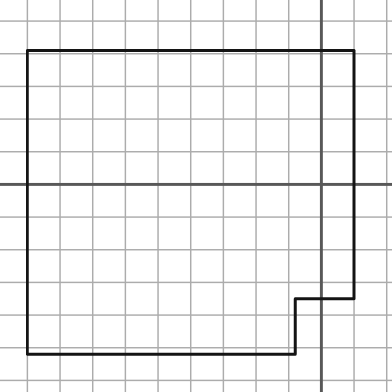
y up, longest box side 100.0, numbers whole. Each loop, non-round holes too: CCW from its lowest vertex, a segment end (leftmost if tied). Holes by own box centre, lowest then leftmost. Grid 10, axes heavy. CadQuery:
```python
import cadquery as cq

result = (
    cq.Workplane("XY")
    .moveTo(-90.0, -52.0)
    .lineTo(-8.0, -52.0)
    .lineTo(-8.0, -35.0)
    .lineTo(10.0, -35.0)
    .lineTo(10.0, 41.0)
    .lineTo(-90.0, 41.0)
    .close()
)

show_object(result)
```